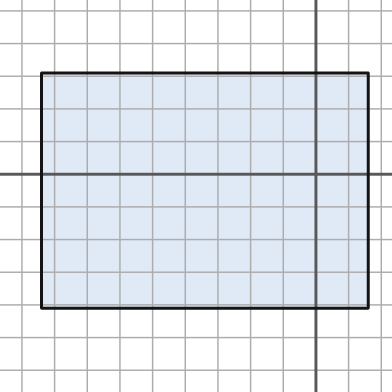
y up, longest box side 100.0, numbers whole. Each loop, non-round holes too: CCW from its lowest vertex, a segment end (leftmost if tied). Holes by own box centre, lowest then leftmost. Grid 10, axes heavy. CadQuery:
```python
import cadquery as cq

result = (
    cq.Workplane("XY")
    .moveTo(-84.0, -41.0)
    .lineTo(16.0, -41.0)
    .lineTo(16.0, 31.0)
    .lineTo(-84.0, 31.0)
    .close()
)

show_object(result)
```